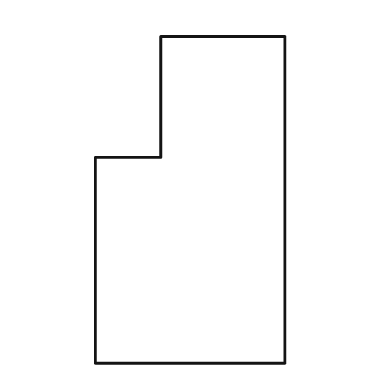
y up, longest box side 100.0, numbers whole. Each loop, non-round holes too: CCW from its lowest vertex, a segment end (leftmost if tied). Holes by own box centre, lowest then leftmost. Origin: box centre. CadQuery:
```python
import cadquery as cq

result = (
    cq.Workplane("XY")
    .moveTo(-29.0, -50.0)
    .lineTo(29.0, -50.0)
    .lineTo(29.0, 50.0)
    .lineTo(-9.0, 50.0)
    .lineTo(-9.0, 13.0)
    .lineTo(-29.0, 13.0)
    .close()
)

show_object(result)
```